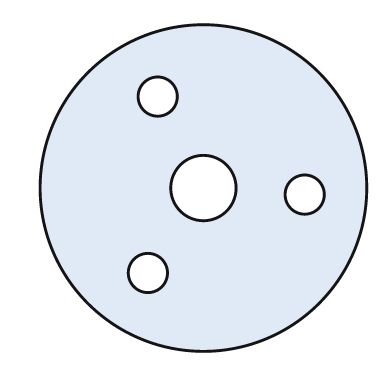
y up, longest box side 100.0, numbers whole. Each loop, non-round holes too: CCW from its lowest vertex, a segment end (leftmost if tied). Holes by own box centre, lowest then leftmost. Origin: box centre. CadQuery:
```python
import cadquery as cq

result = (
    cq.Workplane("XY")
    .moveTo(0.0, 0.0)
    .circle(50.0)
    .moveTo(-17.0, -26.0)
    .circle(6.0)
    .moveTo(31.0, -2.0)
    .circle(6.0)
    .moveTo(0.0, 0.0)
    .circle(10.0)
    .moveTo(-14.0, 28.0)
    .circle(6.0)
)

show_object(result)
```